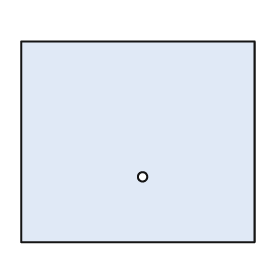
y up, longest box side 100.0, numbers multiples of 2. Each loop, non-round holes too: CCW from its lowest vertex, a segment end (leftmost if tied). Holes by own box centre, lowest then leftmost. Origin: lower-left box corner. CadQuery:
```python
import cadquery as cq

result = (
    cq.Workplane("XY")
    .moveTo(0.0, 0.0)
    .lineTo(100.0, 0.0)
    .lineTo(100.0, 86.0)
    .lineTo(0.0, 86.0)
    .close()
    .moveTo(52.0, 28.0)
    .circle(2.0)
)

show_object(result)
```